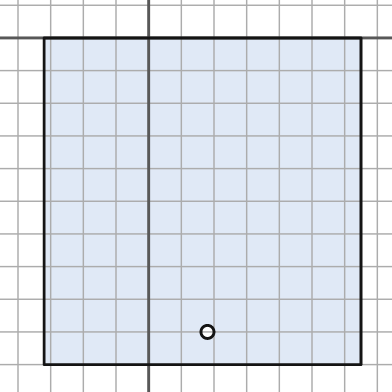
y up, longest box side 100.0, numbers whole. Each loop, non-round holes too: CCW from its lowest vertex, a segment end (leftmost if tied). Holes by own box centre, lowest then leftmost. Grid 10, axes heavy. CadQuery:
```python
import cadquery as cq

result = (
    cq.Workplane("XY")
    .moveTo(-32.0, -100.0)
    .lineTo(65.0, -100.0)
    .lineTo(65.0, 0.0)
    .lineTo(-32.0, 0.0)
    .close()
    .moveTo(18.0, -90.0)
    .circle(2.0)
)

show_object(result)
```